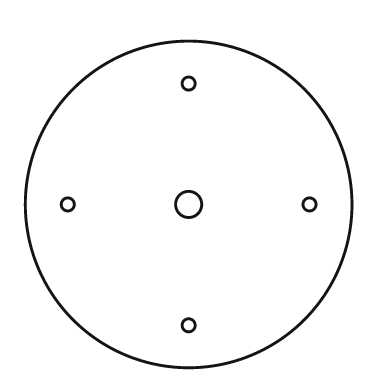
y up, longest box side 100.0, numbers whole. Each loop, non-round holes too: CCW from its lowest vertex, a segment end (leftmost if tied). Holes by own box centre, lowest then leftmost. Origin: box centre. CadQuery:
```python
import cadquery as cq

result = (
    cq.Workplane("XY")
    .moveTo(0.0, 0.0)
    .circle(50.0)
    .moveTo(0.0, -37.0)
    .circle(2.0)
    .moveTo(-37.0, 0.0)
    .circle(2.0)
    .moveTo(0.0, 0.0)
    .circle(4.0)
    .moveTo(37.0, 0.0)
    .circle(2.0)
    .moveTo(0.0, 37.0)
    .circle(2.0)
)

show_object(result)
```